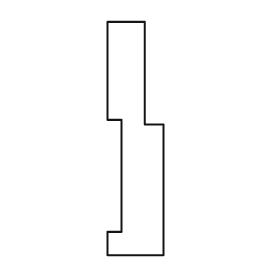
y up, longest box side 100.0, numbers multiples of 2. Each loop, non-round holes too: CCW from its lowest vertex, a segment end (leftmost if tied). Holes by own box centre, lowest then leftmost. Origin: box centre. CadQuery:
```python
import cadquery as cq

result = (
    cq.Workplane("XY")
    .moveTo(-12.0, -50.0)
    .lineTo(12.0, -50.0)
    .lineTo(12.0, 6.0)
    .lineTo(4.0, 6.0)
    .lineTo(4.0, 50.0)
    .lineTo(-12.0, 50.0)
    .lineTo(-12.0, 8.0)
    .lineTo(-6.0, 8.0)
    .lineTo(-6.0, -40.0)
    .lineTo(-12.0, -40.0)
    .close()
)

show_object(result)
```